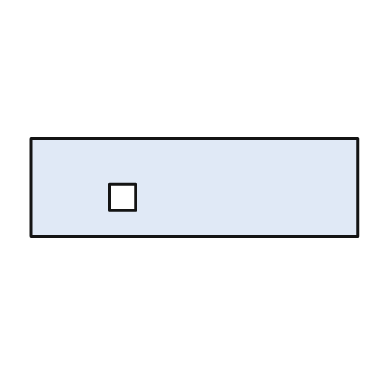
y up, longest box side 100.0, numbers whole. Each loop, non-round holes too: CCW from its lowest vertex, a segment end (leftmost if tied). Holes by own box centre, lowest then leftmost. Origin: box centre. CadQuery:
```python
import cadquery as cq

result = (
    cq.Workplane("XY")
    .moveTo(-50.0, -15.0)
    .lineTo(50.0, -15.0)
    .lineTo(50.0, 15.0)
    .lineTo(-50.0, 15.0)
    .close()
    .moveTo(-26.0, -7.0)
    .lineTo(-18.0, -7.0)
    .lineTo(-18.0, 1.0)
    .lineTo(-26.0, 1.0)
    .close()
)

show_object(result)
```